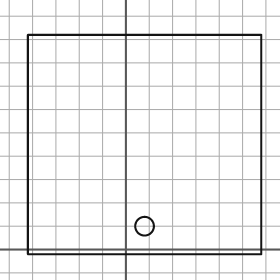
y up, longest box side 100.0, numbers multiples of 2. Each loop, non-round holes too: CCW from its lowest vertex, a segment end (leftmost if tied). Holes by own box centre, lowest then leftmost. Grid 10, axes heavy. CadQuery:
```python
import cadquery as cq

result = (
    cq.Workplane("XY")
    .moveTo(-42.0, -2.0)
    .lineTo(58.0, -2.0)
    .lineTo(58.0, 92.0)
    .lineTo(-42.0, 92.0)
    .close()
    .moveTo(8.0, 10.0)
    .circle(4.0)
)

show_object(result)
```